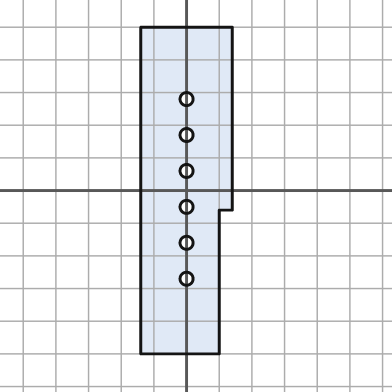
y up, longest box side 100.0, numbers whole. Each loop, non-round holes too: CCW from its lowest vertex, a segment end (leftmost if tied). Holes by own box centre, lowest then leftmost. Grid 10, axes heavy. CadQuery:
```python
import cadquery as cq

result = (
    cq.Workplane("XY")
    .moveTo(-14.0, -50.0)
    .lineTo(10.0, -50.0)
    .lineTo(10.0, -6.0)
    .lineTo(14.0, -6.0)
    .lineTo(14.0, 50.0)
    .lineTo(-14.0, 50.0)
    .close()
    .moveTo(0.0, -27.0)
    .circle(2.0)
    .moveTo(0.0, -16.0)
    .circle(2.0)
    .moveTo(0.0, -5.0)
    .circle(2.0)
    .moveTo(0.0, 6.0)
    .circle(2.0)
    .moveTo(0.0, 17.0)
    .circle(2.0)
    .moveTo(0.0, 28.0)
    .circle(2.0)
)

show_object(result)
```